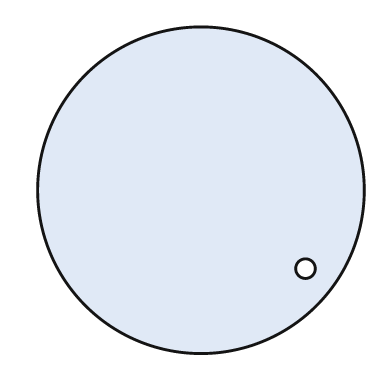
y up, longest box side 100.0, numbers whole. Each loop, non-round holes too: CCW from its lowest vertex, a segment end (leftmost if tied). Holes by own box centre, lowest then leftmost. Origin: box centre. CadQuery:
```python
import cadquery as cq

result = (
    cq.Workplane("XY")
    .moveTo(0.0, 0.0)
    .circle(50.0)
    .moveTo(32.0, -24.0)
    .circle(3.0)
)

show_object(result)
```